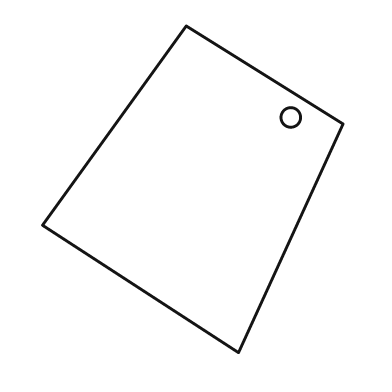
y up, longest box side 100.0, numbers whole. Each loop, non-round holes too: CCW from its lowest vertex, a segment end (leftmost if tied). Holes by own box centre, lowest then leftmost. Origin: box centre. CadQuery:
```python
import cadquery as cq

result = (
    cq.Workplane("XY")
    .moveTo(14.0, -50.0)
    .lineTo(46.0, 20.0)
    .lineTo(-2.0, 50.0)
    .lineTo(-46.0, -11.0)
    .close()
    .moveTo(30.0, 22.0)
    .circle(3.0)
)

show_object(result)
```